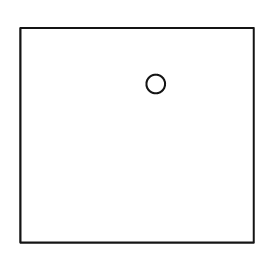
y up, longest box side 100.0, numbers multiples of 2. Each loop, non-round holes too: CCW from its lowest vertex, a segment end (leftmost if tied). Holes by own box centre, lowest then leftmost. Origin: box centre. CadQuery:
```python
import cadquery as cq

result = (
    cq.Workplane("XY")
    .moveTo(-50.0, -46.0)
    .lineTo(50.0, -46.0)
    .lineTo(50.0, 46.0)
    .lineTo(-50.0, 46.0)
    .close()
    .moveTo(8.0, 22.0)
    .circle(4.0)
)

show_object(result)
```